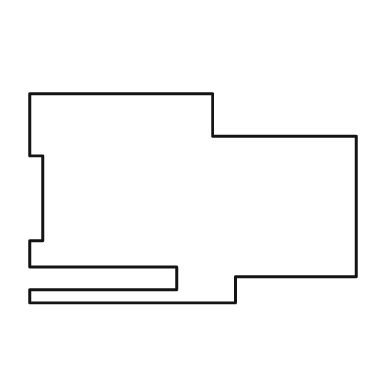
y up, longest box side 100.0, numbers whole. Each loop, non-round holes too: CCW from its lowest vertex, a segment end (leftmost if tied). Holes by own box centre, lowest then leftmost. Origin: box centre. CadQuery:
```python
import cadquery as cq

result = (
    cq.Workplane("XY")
    .moveTo(-50.0, -32.0)
    .lineTo(13.0, -32.0)
    .lineTo(13.0, -24.0)
    .lineTo(50.0, -24.0)
    .lineTo(50.0, 19.0)
    .lineTo(6.0, 19.0)
    .lineTo(6.0, 32.0)
    .lineTo(-50.0, 32.0)
    .lineTo(-50.0, 13.0)
    .lineTo(-46.0, 13.0)
    .lineTo(-46.0, -13.0)
    .lineTo(-50.0, -13.0)
    .lineTo(-50.0, -21.0)
    .lineTo(-5.0, -21.0)
    .lineTo(-5.0, -28.0)
    .lineTo(-50.0, -28.0)
    .close()
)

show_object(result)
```